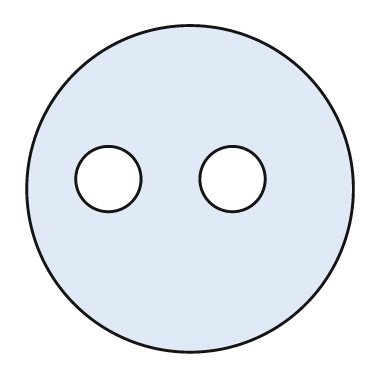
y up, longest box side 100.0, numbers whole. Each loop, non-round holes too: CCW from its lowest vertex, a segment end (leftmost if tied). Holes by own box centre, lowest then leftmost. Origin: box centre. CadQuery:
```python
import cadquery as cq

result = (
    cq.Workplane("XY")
    .moveTo(0.0, 0.0)
    .circle(50.0)
    .moveTo(-25.0, 3.0)
    .circle(10.0)
    .moveTo(13.0, 3.0)
    .circle(10.0)
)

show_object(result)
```